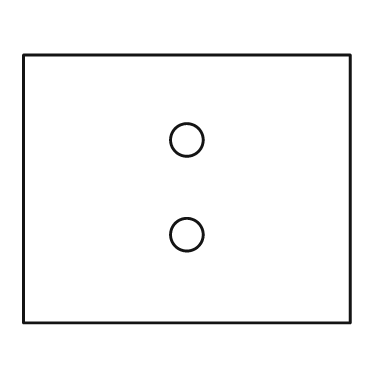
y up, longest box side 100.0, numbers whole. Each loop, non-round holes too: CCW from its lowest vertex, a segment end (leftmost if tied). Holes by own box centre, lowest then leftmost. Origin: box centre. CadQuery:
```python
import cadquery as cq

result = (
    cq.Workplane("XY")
    .moveTo(-50.0, -41.0)
    .lineTo(50.0, -41.0)
    .lineTo(50.0, 41.0)
    .lineTo(-50.0, 41.0)
    .close()
    .moveTo(0.0, -14.0)
    .circle(5.0)
    .moveTo(0.0, 15.0)
    .circle(5.0)
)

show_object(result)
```